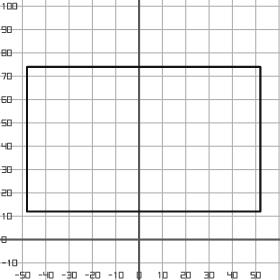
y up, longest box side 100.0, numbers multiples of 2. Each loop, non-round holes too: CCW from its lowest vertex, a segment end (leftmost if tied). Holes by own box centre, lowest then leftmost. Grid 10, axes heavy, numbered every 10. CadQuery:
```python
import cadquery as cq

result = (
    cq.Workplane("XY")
    .moveTo(-48.0, 12.0)
    .lineTo(52.0, 12.0)
    .lineTo(52.0, 74.0)
    .lineTo(-48.0, 74.0)
    .close()
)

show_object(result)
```